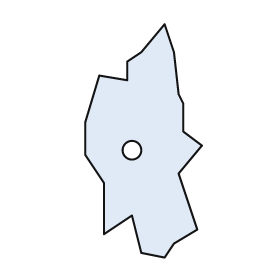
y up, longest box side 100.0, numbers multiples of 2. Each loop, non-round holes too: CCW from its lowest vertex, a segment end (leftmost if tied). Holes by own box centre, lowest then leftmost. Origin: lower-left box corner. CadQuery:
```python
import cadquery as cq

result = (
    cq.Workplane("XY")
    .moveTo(34.0, 0.0)
    .lineTo(38.0, 6.0)
    .lineTo(48.0, 12.0)
    .lineTo(40.0, 36.0)
    .lineTo(50.0, 48.0)
    .lineTo(42.0, 54.0)
    .lineTo(42.0, 66.0)
    .lineTo(40.0, 70.0)
    .lineTo(38.0, 88.0)
    .lineTo(34.0, 100.0)
    .lineTo(24.0, 88.0)
    .lineTo(18.0, 84.0)
    .lineTo(18.0, 76.0)
    .lineTo(6.0, 78.0)
    .lineTo(0.0, 58.0)
    .lineTo(0.0, 44.0)
    .lineTo(8.0, 32.0)
    .lineTo(8.0, 10.0)
    .lineTo(20.0, 18.0)
    .lineTo(24.0, 2.0)
    .close()
    .moveTo(20.0, 46.0)
    .circle(4.0)
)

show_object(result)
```